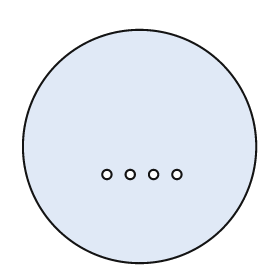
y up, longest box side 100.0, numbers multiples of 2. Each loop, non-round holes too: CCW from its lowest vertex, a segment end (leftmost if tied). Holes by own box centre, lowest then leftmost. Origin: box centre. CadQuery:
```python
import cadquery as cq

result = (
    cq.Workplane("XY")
    .moveTo(0.0, 0.0)
    .circle(50.0)
    .moveTo(-14.0, -12.0)
    .circle(2.0)
    .moveTo(-4.0, -12.0)
    .circle(2.0)
    .moveTo(6.0, -12.0)
    .circle(2.0)
    .moveTo(16.0, -12.0)
    .circle(2.0)
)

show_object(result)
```